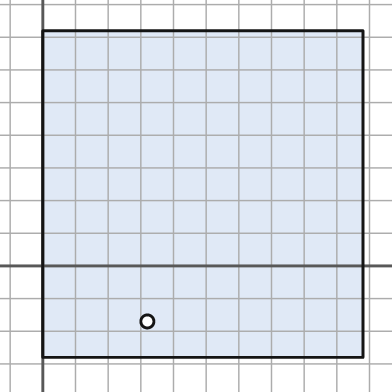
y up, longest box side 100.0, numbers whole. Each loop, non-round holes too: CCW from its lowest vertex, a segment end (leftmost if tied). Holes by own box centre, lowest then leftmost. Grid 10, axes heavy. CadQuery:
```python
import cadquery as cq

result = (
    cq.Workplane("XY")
    .moveTo(0.0, -28.0)
    .lineTo(98.0, -28.0)
    .lineTo(98.0, 72.0)
    .lineTo(0.0, 72.0)
    .close()
    .moveTo(32.0, -17.0)
    .circle(2.0)
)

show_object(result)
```